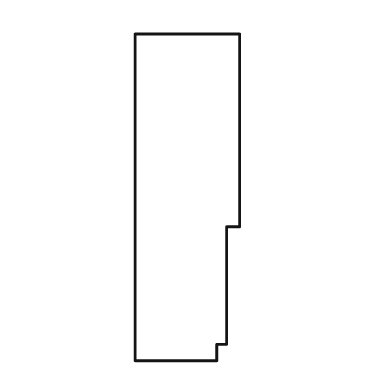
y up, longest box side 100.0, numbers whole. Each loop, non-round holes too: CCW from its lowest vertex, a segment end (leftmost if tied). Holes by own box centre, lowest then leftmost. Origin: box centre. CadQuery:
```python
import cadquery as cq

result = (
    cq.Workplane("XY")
    .moveTo(-16.0, -50.0)
    .lineTo(9.0, -50.0)
    .lineTo(9.0, -45.0)
    .lineTo(12.0, -45.0)
    .lineTo(12.0, -9.0)
    .lineTo(16.0, -9.0)
    .lineTo(16.0, 50.0)
    .lineTo(-16.0, 50.0)
    .close()
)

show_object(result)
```